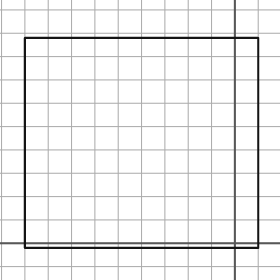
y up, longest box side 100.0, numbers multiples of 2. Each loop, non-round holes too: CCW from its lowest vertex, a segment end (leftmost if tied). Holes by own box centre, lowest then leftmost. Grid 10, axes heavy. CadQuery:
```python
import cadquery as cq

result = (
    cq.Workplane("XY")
    .moveTo(-90.0, -2.0)
    .lineTo(10.0, -2.0)
    .lineTo(10.0, 88.0)
    .lineTo(-90.0, 88.0)
    .close()
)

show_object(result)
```